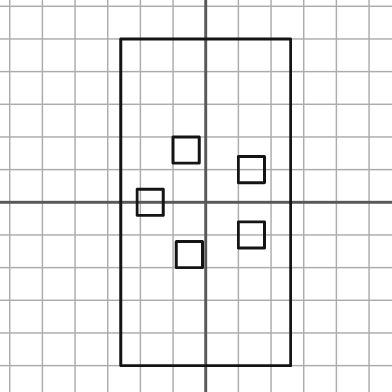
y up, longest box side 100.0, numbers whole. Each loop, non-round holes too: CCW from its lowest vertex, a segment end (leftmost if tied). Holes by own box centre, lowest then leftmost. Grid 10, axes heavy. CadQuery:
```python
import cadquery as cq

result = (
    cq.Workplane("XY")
    .moveTo(-26.0, -50.0)
    .lineTo(26.0, -50.0)
    .lineTo(26.0, 50.0)
    .lineTo(-26.0, 50.0)
    .close()
    .moveTo(-9.0, -20.0)
    .lineTo(-1.0, -20.0)
    .lineTo(-1.0, -12.0)
    .lineTo(-9.0, -12.0)
    .close()
    .moveTo(10.0, -14.0)
    .lineTo(18.0, -14.0)
    .lineTo(18.0, -6.0)
    .lineTo(10.0, -6.0)
    .close()
    .moveTo(-21.0, -4.0)
    .lineTo(-13.0, -4.0)
    .lineTo(-13.0, 4.0)
    .lineTo(-21.0, 4.0)
    .close()
    .moveTo(10.0, 6.0)
    .lineTo(18.0, 6.0)
    .lineTo(18.0, 14.0)
    .lineTo(10.0, 14.0)
    .close()
    .moveTo(-10.0, 12.0)
    .lineTo(-2.0, 12.0)
    .lineTo(-2.0, 20.0)
    .lineTo(-10.0, 20.0)
    .close()
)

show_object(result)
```